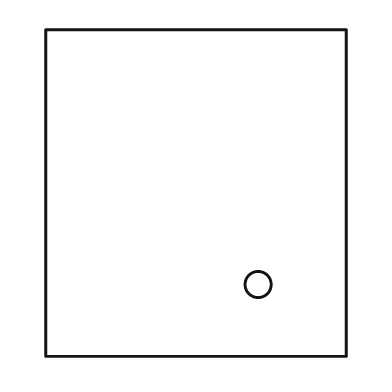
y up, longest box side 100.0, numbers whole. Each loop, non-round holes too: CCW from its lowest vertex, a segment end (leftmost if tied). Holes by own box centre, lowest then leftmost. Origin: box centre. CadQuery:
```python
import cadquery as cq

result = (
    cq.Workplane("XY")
    .moveTo(-46.0, -50.0)
    .lineTo(46.0, -50.0)
    .lineTo(46.0, 50.0)
    .lineTo(-46.0, 50.0)
    .close()
    .moveTo(19.0, -28.0)
    .circle(4.0)
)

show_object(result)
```